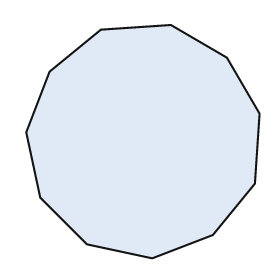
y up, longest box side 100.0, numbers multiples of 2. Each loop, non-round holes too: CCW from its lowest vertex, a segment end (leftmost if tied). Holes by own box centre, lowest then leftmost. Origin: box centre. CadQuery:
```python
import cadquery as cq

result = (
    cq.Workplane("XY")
    .moveTo(4.0, -50.0)
    .lineTo(30.0, -40.0)
    .lineTo(48.0, -18.0)
    .lineTo(50.0, 12.0)
    .lineTo(36.0, 36.0)
    .lineTo(12.0, 50.0)
    .lineTo(-18.0, 48.0)
    .lineTo(-40.0, 30.0)
    .lineTo(-50.0, 4.0)
    .lineTo(-44.0, -24.0)
    .lineTo(-24.0, -44.0)
    .close()
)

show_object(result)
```